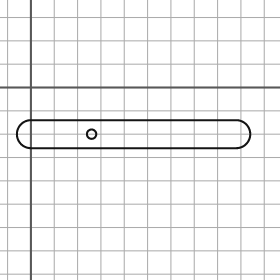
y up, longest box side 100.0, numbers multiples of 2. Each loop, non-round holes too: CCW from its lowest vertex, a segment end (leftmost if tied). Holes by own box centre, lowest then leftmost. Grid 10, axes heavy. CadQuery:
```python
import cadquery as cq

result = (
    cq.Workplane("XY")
    .moveTo(0.0, -26.0)
    .lineTo(88.0, -26.0)
    .threePointArc((94.0, -20.0), (88.0, -14.0))
    .lineTo(0.0, -14.0)
    .threePointArc((-6.0, -20.0), (0.0, -26.0))
    .close()
    .moveTo(26.0, -20.0)
    .circle(2.0)
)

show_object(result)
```